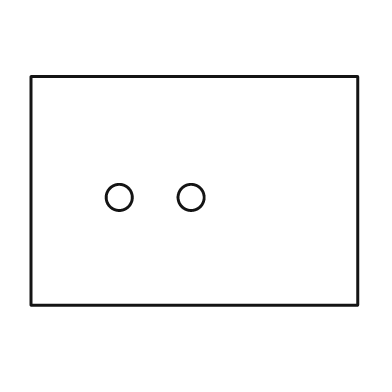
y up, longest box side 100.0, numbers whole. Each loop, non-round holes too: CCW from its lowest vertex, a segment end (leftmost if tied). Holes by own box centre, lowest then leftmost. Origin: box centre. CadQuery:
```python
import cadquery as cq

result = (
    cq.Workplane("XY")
    .moveTo(-50.0, -35.0)
    .lineTo(50.0, -35.0)
    .lineTo(50.0, 35.0)
    .lineTo(-50.0, 35.0)
    .close()
    .moveTo(-23.0, -2.0)
    .circle(4.0)
    .moveTo(-1.0, -2.0)
    .circle(4.0)
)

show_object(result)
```